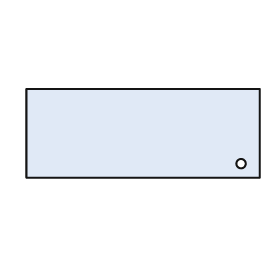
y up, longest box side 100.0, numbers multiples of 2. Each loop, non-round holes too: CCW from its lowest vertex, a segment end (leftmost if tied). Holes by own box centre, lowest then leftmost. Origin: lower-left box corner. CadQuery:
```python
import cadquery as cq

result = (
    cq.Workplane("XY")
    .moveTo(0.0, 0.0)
    .lineTo(100.0, 0.0)
    .lineTo(100.0, 38.0)
    .lineTo(0.0, 38.0)
    .close()
    .moveTo(92.0, 6.0)
    .circle(2.0)
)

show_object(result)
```